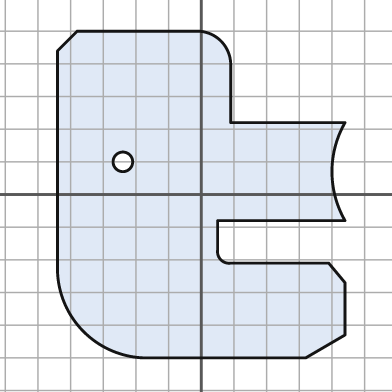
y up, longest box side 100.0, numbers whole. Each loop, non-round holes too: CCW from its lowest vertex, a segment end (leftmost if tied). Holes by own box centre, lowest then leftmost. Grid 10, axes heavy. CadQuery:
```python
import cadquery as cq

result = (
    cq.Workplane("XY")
    .moveTo(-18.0, -50.0)
    .lineTo(32.0, -50.0)
    .lineTo(44.0, -43.0)
    .lineTo(44.0, -27.0)
    .lineTo(39.0, -21.0)
    .lineTo(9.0, -21.0)
    .threePointArc((6.0, -20.0), (5.0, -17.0))
    .lineTo(5.0, -8.0)
    .lineTo(44.0, -8.0)
    .threePointArc((40.0, 7.0), (44.0, 22.0))
    .lineTo(9.0, 22.0)
    .lineTo(9.0, 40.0)
    .threePointArc((6.0, 47.0), (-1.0, 50.0))
    .lineTo(-38.0, 50.0)
    .lineTo(-44.0, 44.0)
    .lineTo(-44.0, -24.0)
    .threePointArc((-36.0, -42.0), (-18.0, -50.0))
    .close()
    .moveTo(-24.0, 10.0)
    .circle(3.0)
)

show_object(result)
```